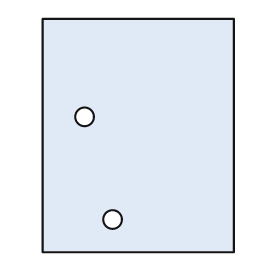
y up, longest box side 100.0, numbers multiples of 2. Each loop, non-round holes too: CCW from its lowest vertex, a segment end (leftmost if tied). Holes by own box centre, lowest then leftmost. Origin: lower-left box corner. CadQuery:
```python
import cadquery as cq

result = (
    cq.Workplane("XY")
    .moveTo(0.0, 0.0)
    .lineTo(82.0, 0.0)
    .lineTo(82.0, 100.0)
    .lineTo(0.0, 100.0)
    .close()
    .moveTo(30.0, 14.0)
    .circle(4.0)
    .moveTo(18.0, 58.0)
    .circle(4.0)
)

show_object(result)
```